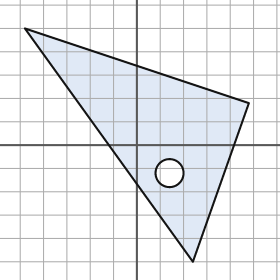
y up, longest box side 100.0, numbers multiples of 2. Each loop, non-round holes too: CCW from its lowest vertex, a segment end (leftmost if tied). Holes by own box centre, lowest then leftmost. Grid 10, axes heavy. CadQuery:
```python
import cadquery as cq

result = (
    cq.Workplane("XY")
    .moveTo(24.0, -50.0)
    .lineTo(48.0, 18.0)
    .lineTo(-48.0, 50.0)
    .close()
    .moveTo(14.0, -12.0)
    .circle(6.0)
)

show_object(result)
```